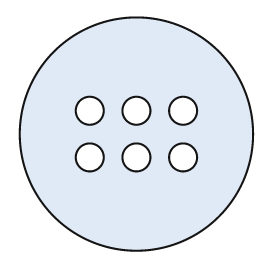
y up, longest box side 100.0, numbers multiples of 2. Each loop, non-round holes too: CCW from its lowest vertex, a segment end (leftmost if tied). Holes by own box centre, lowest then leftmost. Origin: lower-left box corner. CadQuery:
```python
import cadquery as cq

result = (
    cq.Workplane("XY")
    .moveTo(50.0, 50.0)
    .circle(50.0)
    .moveTo(30.0, 40.0)
    .circle(6.0)
    .moveTo(50.0, 40.0)
    .circle(6.0)
    .moveTo(70.0, 40.0)
    .circle(6.0)
    .moveTo(30.0, 60.0)
    .circle(6.0)
    .moveTo(50.0, 60.0)
    .circle(6.0)
    .moveTo(70.0, 60.0)
    .circle(6.0)
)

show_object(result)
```